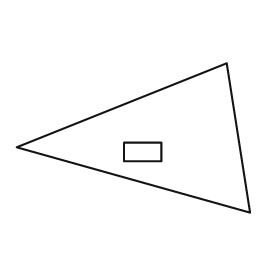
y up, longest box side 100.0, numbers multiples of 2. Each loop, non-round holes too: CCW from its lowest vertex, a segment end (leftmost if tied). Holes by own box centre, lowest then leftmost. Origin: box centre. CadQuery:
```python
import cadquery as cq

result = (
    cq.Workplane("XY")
    .moveTo(50.0, -32.0)
    .lineTo(40.0, 32.0)
    .lineTo(-50.0, -4.0)
    .close()
    .moveTo(-4.0, -10.0)
    .lineTo(12.0, -10.0)
    .lineTo(12.0, -2.0)
    .lineTo(-4.0, -2.0)
    .close()
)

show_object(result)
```